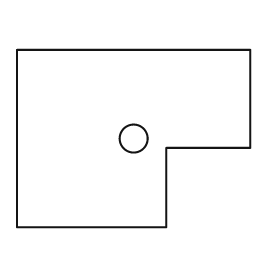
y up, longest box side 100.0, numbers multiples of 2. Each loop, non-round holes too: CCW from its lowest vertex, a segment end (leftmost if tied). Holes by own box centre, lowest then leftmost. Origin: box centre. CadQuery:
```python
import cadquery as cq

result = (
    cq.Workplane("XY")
    .moveTo(-50.0, -38.0)
    .lineTo(14.0, -38.0)
    .lineTo(14.0, -4.0)
    .lineTo(50.0, -4.0)
    .lineTo(50.0, 38.0)
    .lineTo(-50.0, 38.0)
    .close()
    .moveTo(0.0, 0.0)
    .circle(6.0)
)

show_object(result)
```